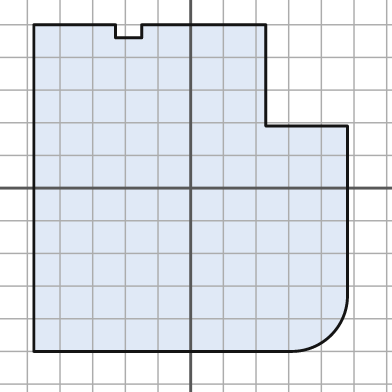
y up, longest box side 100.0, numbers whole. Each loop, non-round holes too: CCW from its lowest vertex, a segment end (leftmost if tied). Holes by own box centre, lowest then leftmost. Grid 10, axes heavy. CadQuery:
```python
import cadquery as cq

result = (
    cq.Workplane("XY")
    .moveTo(-48.0, -50.0)
    .lineTo(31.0, -50.0)
    .threePointArc((43.0, -45.0), (48.0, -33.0))
    .lineTo(48.0, 19.0)
    .lineTo(23.0, 19.0)
    .lineTo(23.0, 50.0)
    .lineTo(-15.0, 50.0)
    .lineTo(-15.0, 46.0)
    .lineTo(-23.0, 46.0)
    .lineTo(-23.0, 50.0)
    .lineTo(-48.0, 50.0)
    .close()
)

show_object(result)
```